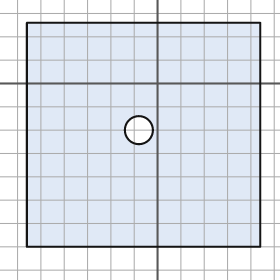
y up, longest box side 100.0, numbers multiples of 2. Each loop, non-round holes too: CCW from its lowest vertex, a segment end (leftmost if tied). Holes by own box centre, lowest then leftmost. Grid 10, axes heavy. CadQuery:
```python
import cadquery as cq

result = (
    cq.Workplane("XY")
    .moveTo(-56.0, -70.0)
    .lineTo(44.0, -70.0)
    .lineTo(44.0, 26.0)
    .lineTo(-56.0, 26.0)
    .close()
    .moveTo(-8.0, -20.0)
    .circle(6.0)
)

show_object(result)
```